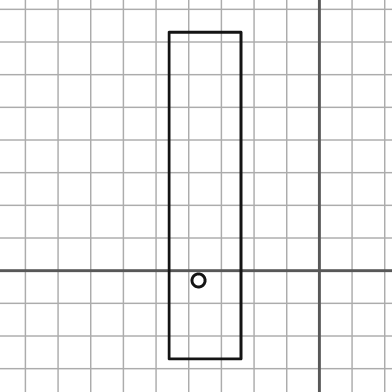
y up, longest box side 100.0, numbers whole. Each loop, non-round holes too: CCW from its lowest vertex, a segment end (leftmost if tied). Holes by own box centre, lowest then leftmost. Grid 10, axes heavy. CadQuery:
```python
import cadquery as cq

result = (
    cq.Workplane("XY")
    .moveTo(-46.0, -27.0)
    .lineTo(-24.0, -27.0)
    .lineTo(-24.0, 73.0)
    .lineTo(-46.0, 73.0)
    .close()
    .moveTo(-37.0, -3.0)
    .circle(2.0)
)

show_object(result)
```